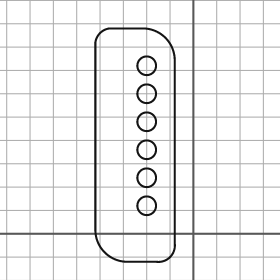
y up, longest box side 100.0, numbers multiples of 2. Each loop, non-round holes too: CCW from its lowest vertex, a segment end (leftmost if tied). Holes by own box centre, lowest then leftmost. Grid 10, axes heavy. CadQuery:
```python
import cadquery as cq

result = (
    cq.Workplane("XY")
    .moveTo(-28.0, -12.0)
    .lineTo(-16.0, -12.0)
    .threePointArc((-10.0, -10.0), (-8.0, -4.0))
    .lineTo(-8.0, 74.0)
    .threePointArc((-12.0, 84.0), (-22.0, 88.0))
    .lineTo(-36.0, 88.0)
    .threePointArc((-40.0, 86.0), (-42.0, 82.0))
    .lineTo(-42.0, 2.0)
    .threePointArc((-38.0, -8.0), (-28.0, -12.0))
    .close()
    .moveTo(-20.0, 12.0)
    .circle(4.0)
    .moveTo(-20.0, 24.0)
    .circle(4.0)
    .moveTo(-20.0, 36.0)
    .circle(4.0)
    .moveTo(-20.0, 48.0)
    .circle(4.0)
    .moveTo(-20.0, 60.0)
    .circle(4.0)
    .moveTo(-20.0, 72.0)
    .circle(4.0)
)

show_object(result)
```